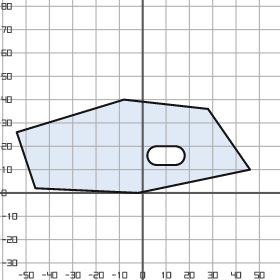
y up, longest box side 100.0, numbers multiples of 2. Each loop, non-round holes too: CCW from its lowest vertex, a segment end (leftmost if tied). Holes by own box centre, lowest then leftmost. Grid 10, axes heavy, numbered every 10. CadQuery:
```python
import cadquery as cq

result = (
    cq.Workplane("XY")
    .moveTo(-2.0, 0.0)
    .lineTo(46.0, 10.0)
    .lineTo(28.0, 36.0)
    .lineTo(-8.0, 40.0)
    .lineTo(-54.0, 26.0)
    .lineTo(-46.0, 2.0)
    .close()
    .moveTo(6.0, 12.0)
    .lineTo(14.0, 12.0)
    .threePointArc((18.0, 16.0), (14.0, 20.0))
    .lineTo(6.0, 20.0)
    .threePointArc((2.0, 16.0), (6.0, 12.0))
    .close()
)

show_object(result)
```